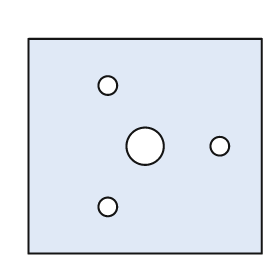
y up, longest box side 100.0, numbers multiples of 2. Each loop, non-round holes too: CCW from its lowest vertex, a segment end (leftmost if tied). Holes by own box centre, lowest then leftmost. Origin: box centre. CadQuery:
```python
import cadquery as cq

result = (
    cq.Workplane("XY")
    .moveTo(-50.0, -46.0)
    .lineTo(50.0, -46.0)
    .lineTo(50.0, 46.0)
    .lineTo(-50.0, 46.0)
    .close()
    .moveTo(-16.0, -26.0)
    .circle(4.0)
    .moveTo(0.0, 0.0)
    .circle(8.0)
    .moveTo(32.0, 0.0)
    .circle(4.0)
    .moveTo(-16.0, 26.0)
    .circle(4.0)
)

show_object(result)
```